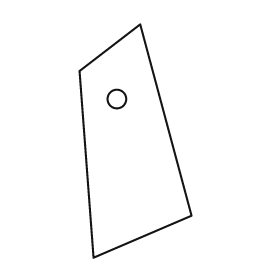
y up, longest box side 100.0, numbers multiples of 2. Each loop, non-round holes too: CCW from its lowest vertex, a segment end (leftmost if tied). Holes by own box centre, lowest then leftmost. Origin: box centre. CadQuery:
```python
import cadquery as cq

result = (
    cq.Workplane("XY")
    .moveTo(-18.0, -50.0)
    .lineTo(24.0, -32.0)
    .lineTo(2.0, 50.0)
    .lineTo(-24.0, 30.0)
    .close()
    .moveTo(-8.0, 18.0)
    .circle(4.0)
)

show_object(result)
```